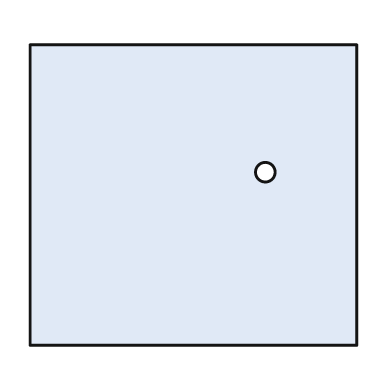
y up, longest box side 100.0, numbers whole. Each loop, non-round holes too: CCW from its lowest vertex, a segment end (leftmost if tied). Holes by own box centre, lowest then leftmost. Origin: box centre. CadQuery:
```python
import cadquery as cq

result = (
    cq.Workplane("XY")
    .moveTo(-50.0, -46.0)
    .lineTo(50.0, -46.0)
    .lineTo(50.0, 46.0)
    .lineTo(-50.0, 46.0)
    .close()
    .moveTo(22.0, 7.0)
    .circle(3.0)
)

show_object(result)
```